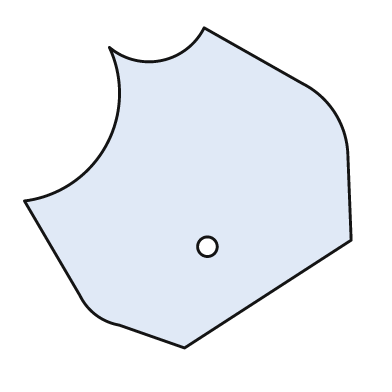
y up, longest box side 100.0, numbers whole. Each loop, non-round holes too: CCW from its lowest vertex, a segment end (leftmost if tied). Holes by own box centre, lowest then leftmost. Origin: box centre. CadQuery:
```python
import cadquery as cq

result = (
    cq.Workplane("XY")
    .moveTo(-1.0, -49.0)
    .lineTo(50.0, -16.0)
    .lineTo(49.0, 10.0)
    .threePointArc((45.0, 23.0), (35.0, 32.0))
    .lineTo(5.0, 49.0)
    .threePointArc((-8.0, 39.0), (-24.0, 43.0))
    .threePointArc((-25.0, 13.0), (-50.0, -4.0))
    .lineTo(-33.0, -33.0)
    .threePointArc((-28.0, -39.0), (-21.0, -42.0))
    .close()
    .moveTo(6.0, -18.0)
    .circle(3.0)
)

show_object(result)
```